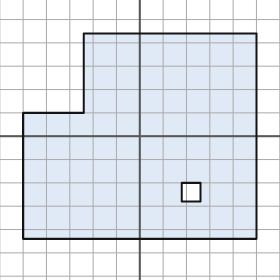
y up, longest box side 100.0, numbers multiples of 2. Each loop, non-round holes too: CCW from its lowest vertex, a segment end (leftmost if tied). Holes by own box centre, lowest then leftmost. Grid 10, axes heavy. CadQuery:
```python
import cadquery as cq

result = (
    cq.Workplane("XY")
    .moveTo(-50.0, -44.0)
    .lineTo(50.0, -44.0)
    .lineTo(50.0, 44.0)
    .lineTo(-24.0, 44.0)
    .lineTo(-24.0, 10.0)
    .lineTo(-50.0, 10.0)
    .close()
    .moveTo(18.0, -28.0)
    .lineTo(26.0, -28.0)
    .lineTo(26.0, -20.0)
    .lineTo(18.0, -20.0)
    .close()
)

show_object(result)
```